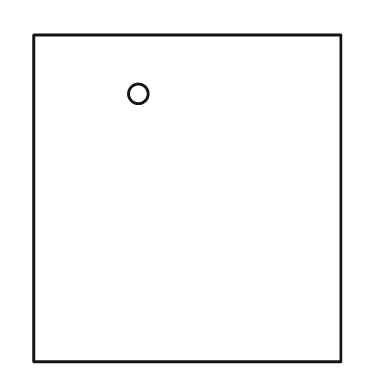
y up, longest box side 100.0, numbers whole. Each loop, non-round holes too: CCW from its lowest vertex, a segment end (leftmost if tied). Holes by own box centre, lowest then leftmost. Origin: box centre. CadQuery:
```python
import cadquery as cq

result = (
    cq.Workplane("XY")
    .moveTo(-47.0, -50.0)
    .lineTo(47.0, -50.0)
    .lineTo(47.0, 50.0)
    .lineTo(-47.0, 50.0)
    .close()
    .moveTo(-15.0, 32.0)
    .circle(3.0)
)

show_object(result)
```